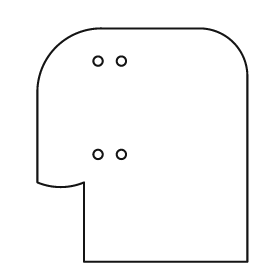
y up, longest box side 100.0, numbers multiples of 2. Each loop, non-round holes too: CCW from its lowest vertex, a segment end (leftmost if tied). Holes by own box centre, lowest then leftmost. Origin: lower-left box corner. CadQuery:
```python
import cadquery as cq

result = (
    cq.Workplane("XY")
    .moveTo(20.0, 0.0)
    .lineTo(90.0, 0.0)
    .lineTo(90.0, 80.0)
    .threePointArc((84.0, 94.0), (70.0, 100.0))
    .lineTo(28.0, 100.0)
    .threePointArc((8.0, 92.0), (0.0, 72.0))
    .lineTo(0.0, 34.0)
    .threePointArc((10.0, 32.0), (20.0, 34.0))
    .close()
    .moveTo(26.0, 46.0)
    .circle(2.0)
    .moveTo(36.0, 46.0)
    .circle(2.0)
    .moveTo(26.0, 86.0)
    .circle(2.0)
    .moveTo(36.0, 86.0)
    .circle(2.0)
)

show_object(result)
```